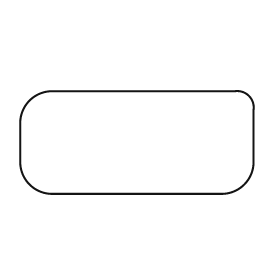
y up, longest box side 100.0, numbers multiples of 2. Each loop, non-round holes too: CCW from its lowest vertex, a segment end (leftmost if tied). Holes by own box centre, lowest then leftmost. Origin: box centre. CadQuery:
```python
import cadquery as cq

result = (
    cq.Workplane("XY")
    .moveTo(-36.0, -22.0)
    .lineTo(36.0, -22.0)
    .threePointArc((46.0, -18.0), (50.0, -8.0))
    .lineTo(50.0, 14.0)
    .threePointArc((48.0, 20.0), (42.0, 22.0))
    .lineTo(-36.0, 22.0)
    .threePointArc((-46.0, 18.0), (-50.0, 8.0))
    .lineTo(-50.0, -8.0)
    .threePointArc((-46.0, -18.0), (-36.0, -22.0))
    .close()
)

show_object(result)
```